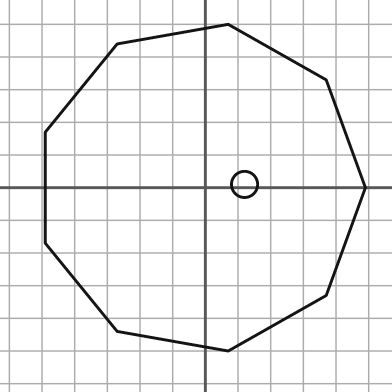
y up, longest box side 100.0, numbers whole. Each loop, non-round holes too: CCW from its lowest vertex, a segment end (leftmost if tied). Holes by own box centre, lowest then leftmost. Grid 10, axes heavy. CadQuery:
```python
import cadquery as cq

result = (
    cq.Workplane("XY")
    .moveTo(7.0, -50.0)
    .lineTo(37.0, -33.0)
    .lineTo(49.0, 0.0)
    .lineTo(37.0, 33.0)
    .lineTo(7.0, 50.0)
    .lineTo(-27.0, 44.0)
    .lineTo(-49.0, 17.0)
    .lineTo(-49.0, -17.0)
    .lineTo(-27.0, -44.0)
    .close()
    .moveTo(12.0, 1.0)
    .circle(4.0)
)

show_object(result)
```